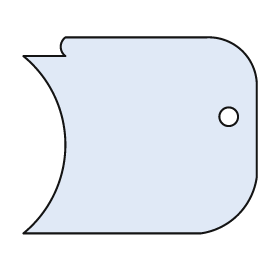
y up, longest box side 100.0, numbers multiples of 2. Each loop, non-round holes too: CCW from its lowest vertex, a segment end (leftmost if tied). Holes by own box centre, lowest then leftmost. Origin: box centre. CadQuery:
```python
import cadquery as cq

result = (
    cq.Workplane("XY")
    .moveTo(-50.0, -42.0)
    .lineTo(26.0, -42.0)
    .threePointArc((42.0, -34.0), (50.0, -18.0))
    .lineTo(50.0, 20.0)
    .threePointArc((44.0, 36.0), (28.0, 42.0))
    .lineTo(-32.0, 42.0)
    .threePointArc((-34.0, 38.0), (-32.0, 34.0))
    .lineTo(-50.0, 34.0)
    .threePointArc((-32.0, -4.0), (-50.0, -42.0))
    .close()
    .moveTo(38.0, 8.0)
    .circle(4.0)
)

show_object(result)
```